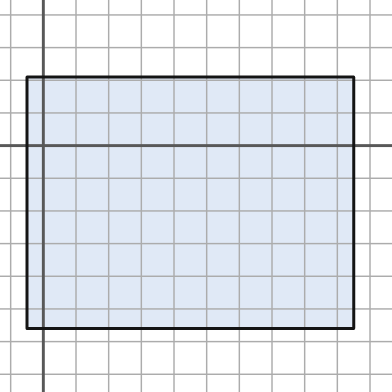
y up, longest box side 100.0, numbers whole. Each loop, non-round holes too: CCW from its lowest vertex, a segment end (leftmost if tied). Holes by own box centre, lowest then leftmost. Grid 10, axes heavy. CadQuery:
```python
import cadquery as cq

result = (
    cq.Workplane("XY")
    .moveTo(-5.0, -56.0)
    .lineTo(95.0, -56.0)
    .lineTo(95.0, 21.0)
    .lineTo(-5.0, 21.0)
    .close()
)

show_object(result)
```